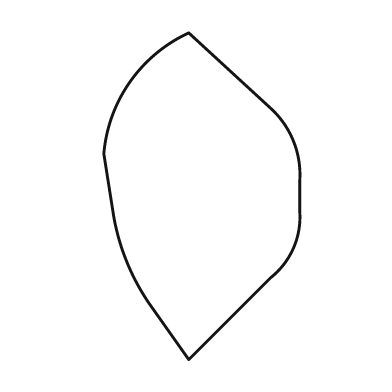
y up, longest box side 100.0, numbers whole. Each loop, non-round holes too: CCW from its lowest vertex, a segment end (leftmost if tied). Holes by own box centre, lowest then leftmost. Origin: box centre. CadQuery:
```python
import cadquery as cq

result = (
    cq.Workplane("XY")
    .moveTo(-4.0, -50.0)
    .lineTo(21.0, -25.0)
    .threePointArc((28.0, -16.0), (30.0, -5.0))
    .lineTo(30.0, 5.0)
    .threePointArc((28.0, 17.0), (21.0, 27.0))
    .lineTo(-4.0, 50.0)
    .threePointArc((-22.0, 35.0), (-30.0, 13.0))
    .lineTo(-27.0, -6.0)
    .threePointArc((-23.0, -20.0), (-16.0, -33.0))
    .close()
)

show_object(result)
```